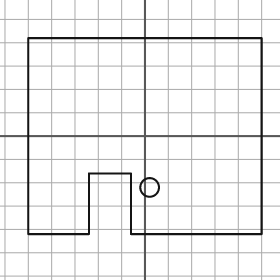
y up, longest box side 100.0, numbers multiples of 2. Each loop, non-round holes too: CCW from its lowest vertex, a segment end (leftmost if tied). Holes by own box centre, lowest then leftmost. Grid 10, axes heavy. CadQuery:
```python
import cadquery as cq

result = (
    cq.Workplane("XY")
    .moveTo(-50.0, -42.0)
    .lineTo(-24.0, -42.0)
    .lineTo(-24.0, -16.0)
    .lineTo(-6.0, -16.0)
    .lineTo(-6.0, -42.0)
    .lineTo(50.0, -42.0)
    .lineTo(50.0, 42.0)
    .lineTo(-50.0, 42.0)
    .close()
    .moveTo(2.0, -22.0)
    .circle(4.0)
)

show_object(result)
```